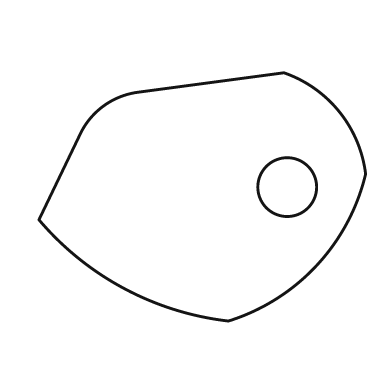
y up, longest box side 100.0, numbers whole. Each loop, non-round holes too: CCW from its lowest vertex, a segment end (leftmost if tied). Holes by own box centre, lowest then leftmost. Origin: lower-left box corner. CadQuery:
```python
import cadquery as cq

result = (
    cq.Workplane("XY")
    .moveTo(58.0, 0.0)
    .threePointArc((85.0, 17.0), (100.0, 45.0))
    .threePointArc((92.0, 64.0), (75.0, 76.0))
    .lineTo(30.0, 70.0)
    .threePointArc((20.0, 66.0), (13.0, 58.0))
    .lineTo(0.0, 31.0)
    .threePointArc((26.0, 10.0), (58.0, 0.0))
    .close()
    .moveTo(76.0, 41.0)
    .circle(9.0)
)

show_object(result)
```